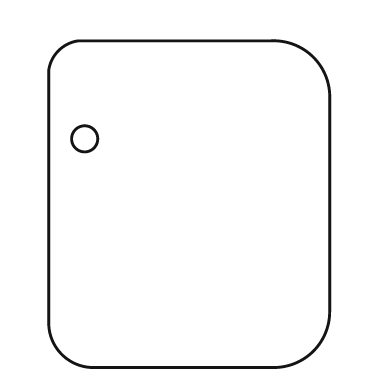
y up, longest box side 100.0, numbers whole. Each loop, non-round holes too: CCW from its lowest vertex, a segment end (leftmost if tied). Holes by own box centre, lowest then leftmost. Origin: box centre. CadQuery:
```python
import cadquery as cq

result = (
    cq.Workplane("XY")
    .moveTo(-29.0, -50.0)
    .lineTo(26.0, -50.0)
    .threePointArc((38.0, -45.0), (43.0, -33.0))
    .lineTo(43.0, 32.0)
    .threePointArc((38.0, 45.0), (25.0, 50.0))
    .lineTo(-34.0, 50.0)
    .threePointArc((-40.0, 47.0), (-43.0, 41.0))
    .lineTo(-43.0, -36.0)
    .threePointArc((-39.0, -46.0), (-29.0, -50.0))
    .close()
    .moveTo(-32.0, 20.0)
    .circle(4.0)
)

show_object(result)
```